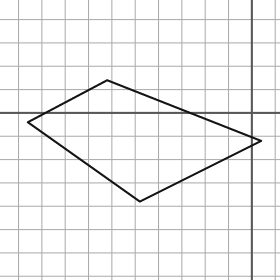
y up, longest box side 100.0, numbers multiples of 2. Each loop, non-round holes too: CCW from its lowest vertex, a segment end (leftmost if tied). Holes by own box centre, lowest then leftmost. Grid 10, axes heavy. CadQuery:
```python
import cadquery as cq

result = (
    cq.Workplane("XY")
    .moveTo(-48.0, -38.0)
    .lineTo(4.0, -12.0)
    .lineTo(-62.0, 14.0)
    .lineTo(-96.0, -4.0)
    .close()
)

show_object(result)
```